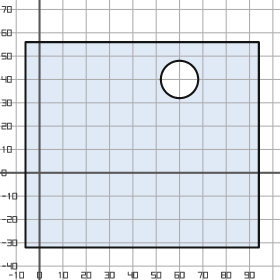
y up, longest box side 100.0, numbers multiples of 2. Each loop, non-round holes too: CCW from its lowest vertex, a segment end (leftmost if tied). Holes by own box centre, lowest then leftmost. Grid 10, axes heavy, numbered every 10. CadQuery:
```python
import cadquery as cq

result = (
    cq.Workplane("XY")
    .moveTo(-6.0, -32.0)
    .lineTo(94.0, -32.0)
    .lineTo(94.0, 56.0)
    .lineTo(-6.0, 56.0)
    .close()
    .moveTo(60.0, 40.0)
    .circle(8.0)
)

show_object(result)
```